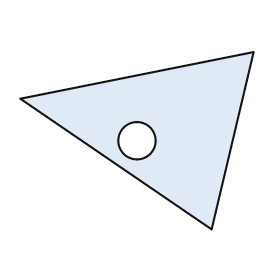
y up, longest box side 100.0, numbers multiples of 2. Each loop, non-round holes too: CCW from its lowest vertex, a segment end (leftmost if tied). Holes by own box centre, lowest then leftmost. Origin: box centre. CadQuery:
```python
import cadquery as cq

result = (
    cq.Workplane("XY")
    .moveTo(32.0, -38.0)
    .lineTo(50.0, 38.0)
    .lineTo(-50.0, 18.0)
    .close()
    .moveTo(0.0, 0.0)
    .circle(8.0)
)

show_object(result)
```